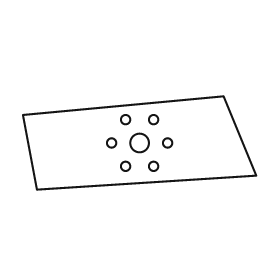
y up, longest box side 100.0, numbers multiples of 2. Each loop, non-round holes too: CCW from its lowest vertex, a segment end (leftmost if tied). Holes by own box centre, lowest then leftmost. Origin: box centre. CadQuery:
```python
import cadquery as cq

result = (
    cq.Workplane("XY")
    .moveTo(-44.0, -20.0)
    .lineTo(50.0, -14.0)
    .lineTo(36.0, 20.0)
    .lineTo(-50.0, 12.0)
    .close()
    .moveTo(-6.0, -10.0)
    .circle(2.0)
    .moveTo(6.0, -10.0)
    .circle(2.0)
    .moveTo(-12.0, 0.0)
    .circle(2.0)
    .moveTo(0.0, 0.0)
    .circle(4.0)
    .moveTo(12.0, 0.0)
    .circle(2.0)
    .moveTo(-6.0, 10.0)
    .circle(2.0)
    .moveTo(6.0, 10.0)
    .circle(2.0)
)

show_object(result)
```